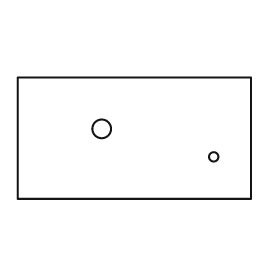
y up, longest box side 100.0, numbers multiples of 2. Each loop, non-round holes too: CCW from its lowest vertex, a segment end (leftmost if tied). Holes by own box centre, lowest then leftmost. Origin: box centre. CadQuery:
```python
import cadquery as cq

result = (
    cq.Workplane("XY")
    .moveTo(-50.0, -26.0)
    .lineTo(50.0, -26.0)
    .lineTo(50.0, 26.0)
    .lineTo(-50.0, 26.0)
    .close()
    .moveTo(34.0, -8.0)
    .circle(2.0)
    .moveTo(-14.0, 4.0)
    .circle(4.0)
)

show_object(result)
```